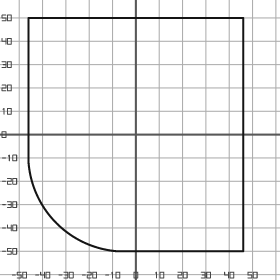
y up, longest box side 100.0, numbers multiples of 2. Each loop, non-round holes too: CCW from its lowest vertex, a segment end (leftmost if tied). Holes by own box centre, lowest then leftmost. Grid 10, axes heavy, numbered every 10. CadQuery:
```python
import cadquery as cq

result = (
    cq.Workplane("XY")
    .moveTo(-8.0, -50.0)
    .lineTo(46.0, -50.0)
    .lineTo(46.0, 50.0)
    .lineTo(-46.0, 50.0)
    .lineTo(-46.0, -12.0)
    .threePointArc((-34.0, -38.0), (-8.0, -50.0))
    .close()
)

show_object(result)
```